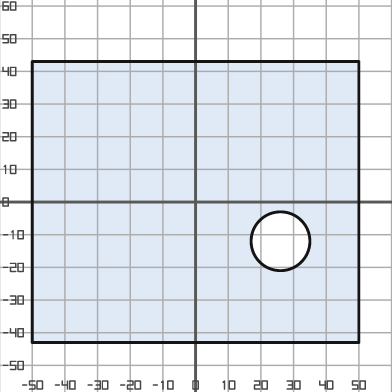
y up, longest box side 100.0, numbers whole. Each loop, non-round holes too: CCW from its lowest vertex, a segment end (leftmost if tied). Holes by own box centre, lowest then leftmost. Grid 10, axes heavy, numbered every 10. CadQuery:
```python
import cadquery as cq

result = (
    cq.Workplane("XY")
    .moveTo(-50.0, -43.0)
    .lineTo(50.0, -43.0)
    .lineTo(50.0, 43.0)
    .lineTo(-50.0, 43.0)
    .close()
    .moveTo(26.0, -12.0)
    .circle(9.0)
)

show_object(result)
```